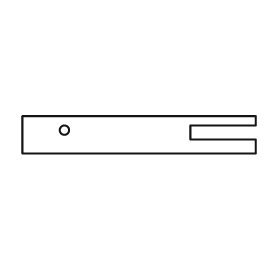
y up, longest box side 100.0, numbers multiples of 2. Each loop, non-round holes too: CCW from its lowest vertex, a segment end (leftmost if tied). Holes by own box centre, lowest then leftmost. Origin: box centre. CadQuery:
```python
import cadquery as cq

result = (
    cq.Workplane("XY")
    .moveTo(-50.0, -8.0)
    .lineTo(50.0, -8.0)
    .lineTo(50.0, -2.0)
    .lineTo(22.0, -2.0)
    .lineTo(22.0, 4.0)
    .lineTo(50.0, 4.0)
    .lineTo(50.0, 8.0)
    .lineTo(-50.0, 8.0)
    .close()
    .moveTo(-32.0, 2.0)
    .circle(2.0)
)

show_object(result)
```